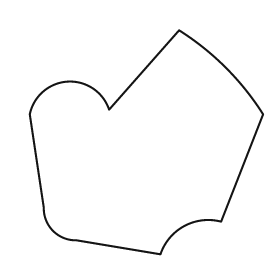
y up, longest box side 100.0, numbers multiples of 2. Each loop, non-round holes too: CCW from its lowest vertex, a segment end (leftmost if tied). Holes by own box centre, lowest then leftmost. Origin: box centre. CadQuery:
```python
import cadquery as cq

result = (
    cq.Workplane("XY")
    .moveTo(6.0, -48.0)
    .threePointArc((16.0, -36.0), (32.0, -34.0))
    .lineTo(50.0, 12.0)
    .threePointArc((34.0, 32.0), (14.0, 48.0))
    .lineTo(-16.0, 14.0)
    .threePointArc((-34.0, 26.0), (-50.0, 12.0))
    .lineTo(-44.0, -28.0)
    .threePointArc((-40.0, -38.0), (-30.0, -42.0))
    .close()
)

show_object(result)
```